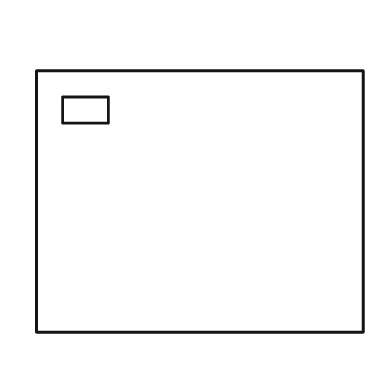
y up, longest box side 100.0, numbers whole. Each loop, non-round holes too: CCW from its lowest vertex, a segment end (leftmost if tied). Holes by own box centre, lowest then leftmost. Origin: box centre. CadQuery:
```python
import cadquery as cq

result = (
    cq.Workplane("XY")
    .moveTo(-50.0, -40.0)
    .lineTo(50.0, -40.0)
    .lineTo(50.0, 40.0)
    .lineTo(-50.0, 40.0)
    .close()
    .moveTo(-42.0, 24.0)
    .lineTo(-28.0, 24.0)
    .lineTo(-28.0, 32.0)
    .lineTo(-42.0, 32.0)
    .close()
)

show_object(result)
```